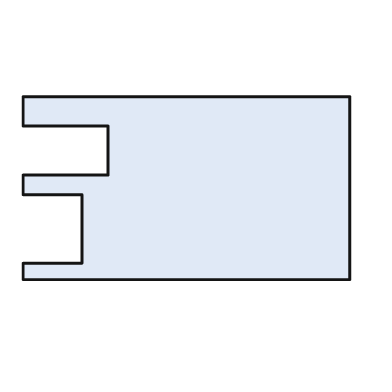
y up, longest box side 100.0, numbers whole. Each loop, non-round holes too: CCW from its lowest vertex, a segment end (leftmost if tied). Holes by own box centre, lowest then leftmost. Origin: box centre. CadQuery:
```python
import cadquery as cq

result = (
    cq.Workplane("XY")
    .moveTo(-50.0, -28.0)
    .lineTo(50.0, -28.0)
    .lineTo(50.0, 28.0)
    .lineTo(-50.0, 28.0)
    .lineTo(-50.0, 19.0)
    .lineTo(-24.0, 19.0)
    .lineTo(-24.0, 4.0)
    .lineTo(-50.0, 4.0)
    .lineTo(-50.0, -2.0)
    .lineTo(-32.0, -2.0)
    .lineTo(-32.0, -23.0)
    .lineTo(-50.0, -23.0)
    .close()
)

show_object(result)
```